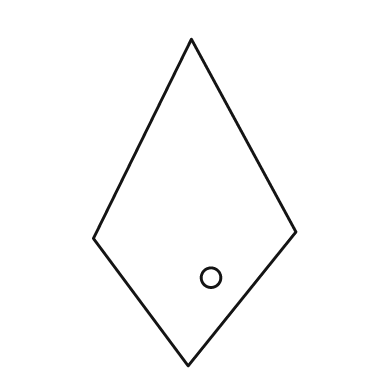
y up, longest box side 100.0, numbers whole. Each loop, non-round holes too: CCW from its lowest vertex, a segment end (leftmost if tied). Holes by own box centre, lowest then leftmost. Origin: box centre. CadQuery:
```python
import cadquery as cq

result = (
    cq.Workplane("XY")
    .moveTo(-2.0, -50.0)
    .lineTo(31.0, -9.0)
    .lineTo(-1.0, 50.0)
    .lineTo(-31.0, -11.0)
    .close()
    .moveTo(5.0, -23.0)
    .circle(3.0)
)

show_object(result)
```